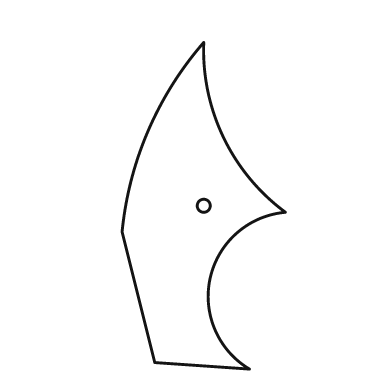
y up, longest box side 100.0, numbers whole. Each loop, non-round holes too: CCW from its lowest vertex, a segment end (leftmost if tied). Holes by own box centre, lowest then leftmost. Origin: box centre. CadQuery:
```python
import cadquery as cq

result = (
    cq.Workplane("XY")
    .moveTo(14.0, -50.0)
    .threePointArc((2.0, -22.0), (25.0, -2.0))
    .threePointArc((6.0, 21.0), (0.0, 50.0))
    .threePointArc((-17.0, 23.0), (-25.0, -8.0))
    .lineTo(-15.0, -48.0)
    .close()
    .moveTo(0.0, 0.0)
    .circle(2.0)
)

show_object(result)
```